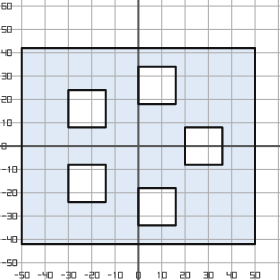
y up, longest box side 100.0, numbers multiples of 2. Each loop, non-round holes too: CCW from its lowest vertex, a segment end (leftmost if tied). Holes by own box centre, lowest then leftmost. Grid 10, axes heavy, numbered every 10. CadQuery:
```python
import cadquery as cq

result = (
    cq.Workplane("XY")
    .moveTo(-50.0, -42.0)
    .lineTo(50.0, -42.0)
    .lineTo(50.0, 42.0)
    .lineTo(-50.0, 42.0)
    .close()
    .moveTo(0.0, -34.0)
    .lineTo(16.0, -34.0)
    .lineTo(16.0, -18.0)
    .lineTo(0.0, -18.0)
    .close()
    .moveTo(-30.0, -24.0)
    .lineTo(-14.0, -24.0)
    .lineTo(-14.0, -8.0)
    .lineTo(-30.0, -8.0)
    .close()
    .moveTo(20.0, -8.0)
    .lineTo(36.0, -8.0)
    .lineTo(36.0, 8.0)
    .lineTo(20.0, 8.0)
    .close()
    .moveTo(-30.0, 8.0)
    .lineTo(-14.0, 8.0)
    .lineTo(-14.0, 24.0)
    .lineTo(-30.0, 24.0)
    .close()
    .moveTo(0.0, 18.0)
    .lineTo(16.0, 18.0)
    .lineTo(16.0, 34.0)
    .lineTo(0.0, 34.0)
    .close()
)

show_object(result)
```